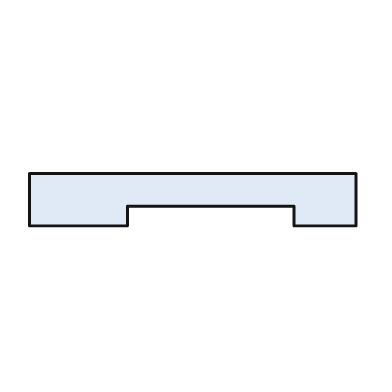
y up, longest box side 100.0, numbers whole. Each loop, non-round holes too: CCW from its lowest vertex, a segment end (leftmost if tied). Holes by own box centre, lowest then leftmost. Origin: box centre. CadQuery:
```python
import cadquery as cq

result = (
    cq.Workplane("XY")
    .moveTo(-50.0, -8.0)
    .lineTo(-20.0, -8.0)
    .lineTo(-20.0, -2.0)
    .lineTo(31.0, -2.0)
    .lineTo(31.0, -8.0)
    .lineTo(50.0, -8.0)
    .lineTo(50.0, 8.0)
    .lineTo(-50.0, 8.0)
    .close()
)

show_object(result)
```